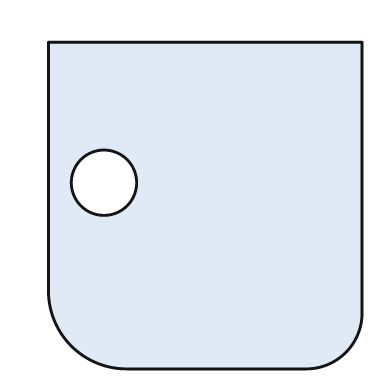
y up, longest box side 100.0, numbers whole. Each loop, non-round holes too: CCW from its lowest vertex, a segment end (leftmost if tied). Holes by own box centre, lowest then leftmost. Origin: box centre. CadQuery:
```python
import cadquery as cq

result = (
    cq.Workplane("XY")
    .moveTo(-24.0, -50.0)
    .lineTo(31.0, -50.0)
    .threePointArc((43.0, -45.0), (48.0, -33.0))
    .lineTo(48.0, 50.0)
    .lineTo(-48.0, 50.0)
    .lineTo(-48.0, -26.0)
    .threePointArc((-41.0, -43.0), (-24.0, -50.0))
    .close()
    .moveTo(-31.0, 7.0)
    .circle(10.0)
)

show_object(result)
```